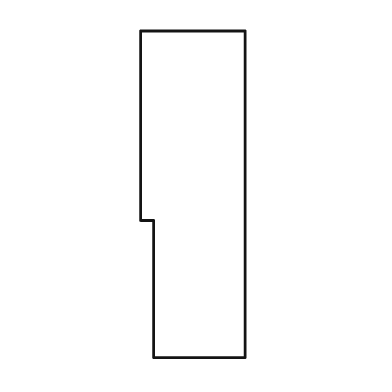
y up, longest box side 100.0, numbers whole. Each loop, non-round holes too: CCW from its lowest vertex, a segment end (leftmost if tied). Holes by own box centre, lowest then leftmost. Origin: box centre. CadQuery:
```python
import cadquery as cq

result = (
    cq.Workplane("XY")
    .moveTo(-12.0, -50.0)
    .lineTo(16.0, -50.0)
    .lineTo(16.0, 50.0)
    .lineTo(-16.0, 50.0)
    .lineTo(-16.0, -8.0)
    .lineTo(-12.0, -8.0)
    .close()
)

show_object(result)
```